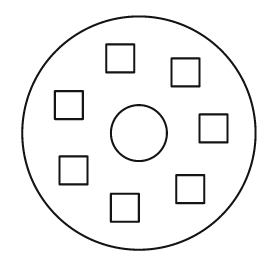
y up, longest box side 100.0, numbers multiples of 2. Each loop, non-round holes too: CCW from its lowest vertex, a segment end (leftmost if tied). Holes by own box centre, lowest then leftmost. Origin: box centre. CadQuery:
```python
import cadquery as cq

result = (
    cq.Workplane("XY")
    .moveTo(0.0, 0.0)
    .circle(50.0)
    .moveTo(-12.0, -38.0)
    .lineTo(0.0, -38.0)
    .lineTo(0.0, -26.0)
    .lineTo(-12.0, -26.0)
    .close()
    .moveTo(16.0, -30.0)
    .lineTo(28.0, -30.0)
    .lineTo(28.0, -18.0)
    .lineTo(16.0, -18.0)
    .close()
    .moveTo(-34.0, -22.0)
    .lineTo(-22.0, -22.0)
    .lineTo(-22.0, -10.0)
    .lineTo(-34.0, -10.0)
    .close()
    .moveTo(0.0, 0.0)
    .circle(12.0)
    .moveTo(26.0, -4.0)
    .lineTo(38.0, -4.0)
    .lineTo(38.0, 8.0)
    .lineTo(26.0, 8.0)
    .close()
    .moveTo(-36.0, 6.0)
    .lineTo(-24.0, 6.0)
    .lineTo(-24.0, 18.0)
    .lineTo(-36.0, 18.0)
    .close()
    .moveTo(14.0, 20.0)
    .lineTo(26.0, 20.0)
    .lineTo(26.0, 32.0)
    .lineTo(14.0, 32.0)
    .close()
    .moveTo(-14.0, 26.0)
    .lineTo(-2.0, 26.0)
    .lineTo(-2.0, 38.0)
    .lineTo(-14.0, 38.0)
    .close()
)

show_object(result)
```